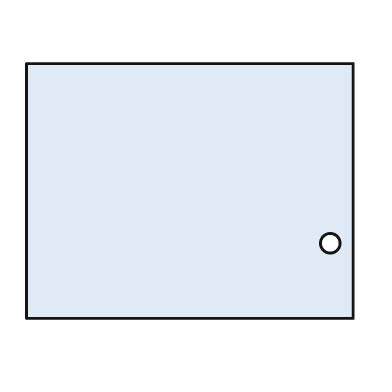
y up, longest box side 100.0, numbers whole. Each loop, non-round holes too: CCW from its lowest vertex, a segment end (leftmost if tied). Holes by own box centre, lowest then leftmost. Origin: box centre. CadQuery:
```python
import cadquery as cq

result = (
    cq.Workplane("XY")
    .moveTo(-50.0, -39.0)
    .lineTo(50.0, -39.0)
    .lineTo(50.0, 39.0)
    .lineTo(-50.0, 39.0)
    .close()
    .moveTo(43.0, -16.0)
    .circle(3.0)
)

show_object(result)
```